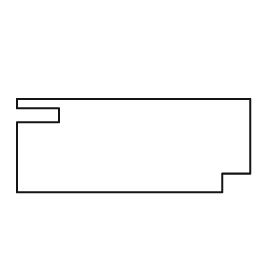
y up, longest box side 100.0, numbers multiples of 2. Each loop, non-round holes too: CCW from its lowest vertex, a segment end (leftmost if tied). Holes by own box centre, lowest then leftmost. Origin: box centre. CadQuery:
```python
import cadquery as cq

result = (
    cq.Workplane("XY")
    .moveTo(-50.0, -20.0)
    .lineTo(38.0, -20.0)
    .lineTo(38.0, -12.0)
    .lineTo(50.0, -12.0)
    .lineTo(50.0, 20.0)
    .lineTo(-50.0, 20.0)
    .lineTo(-50.0, 16.0)
    .lineTo(-32.0, 16.0)
    .lineTo(-32.0, 10.0)
    .lineTo(-50.0, 10.0)
    .close()
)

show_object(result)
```